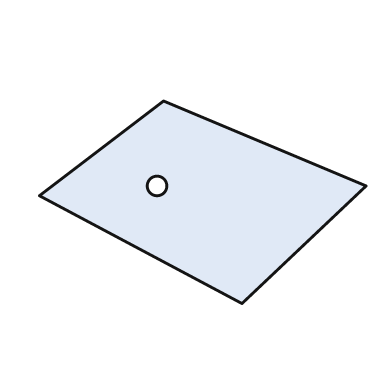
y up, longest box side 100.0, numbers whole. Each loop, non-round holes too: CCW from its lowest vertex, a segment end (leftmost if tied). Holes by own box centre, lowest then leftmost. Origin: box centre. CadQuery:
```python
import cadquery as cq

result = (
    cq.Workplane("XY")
    .moveTo(12.0, -31.0)
    .lineTo(50.0, 5.0)
    .lineTo(-12.0, 31.0)
    .lineTo(-50.0, 2.0)
    .close()
    .moveTo(-14.0, 5.0)
    .circle(3.0)
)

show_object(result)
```